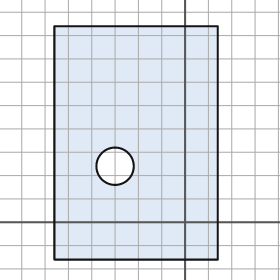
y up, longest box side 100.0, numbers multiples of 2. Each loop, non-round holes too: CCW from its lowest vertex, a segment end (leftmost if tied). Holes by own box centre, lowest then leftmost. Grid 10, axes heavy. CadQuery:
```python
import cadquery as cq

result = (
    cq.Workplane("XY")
    .moveTo(-56.0, -16.0)
    .lineTo(14.0, -16.0)
    .lineTo(14.0, 84.0)
    .lineTo(-56.0, 84.0)
    .close()
    .moveTo(-30.0, 24.0)
    .circle(8.0)
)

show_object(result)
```